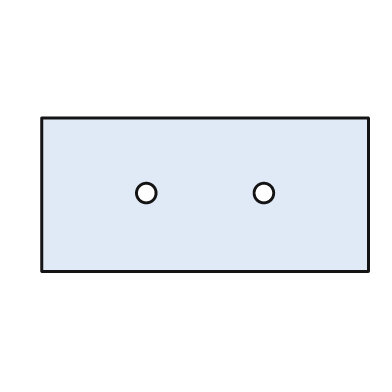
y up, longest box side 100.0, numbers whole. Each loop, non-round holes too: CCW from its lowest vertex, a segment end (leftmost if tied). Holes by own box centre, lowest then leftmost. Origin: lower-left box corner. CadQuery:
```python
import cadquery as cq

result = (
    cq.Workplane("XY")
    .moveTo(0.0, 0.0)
    .lineTo(100.0, 0.0)
    .lineTo(100.0, 47.0)
    .lineTo(0.0, 47.0)
    .close()
    .moveTo(32.0, 24.0)
    .circle(3.0)
    .moveTo(68.0, 24.0)
    .circle(3.0)
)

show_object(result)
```